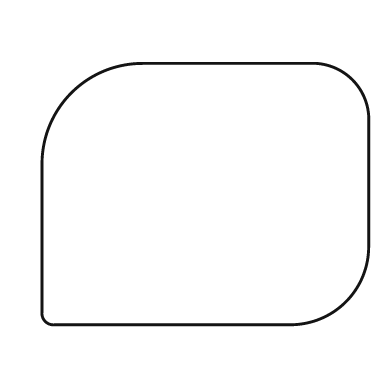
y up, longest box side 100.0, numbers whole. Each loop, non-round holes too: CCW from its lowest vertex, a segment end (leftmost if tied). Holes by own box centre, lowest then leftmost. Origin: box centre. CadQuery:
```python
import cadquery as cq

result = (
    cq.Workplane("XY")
    .moveTo(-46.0, -40.0)
    .lineTo(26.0, -40.0)
    .threePointArc((43.0, -33.0), (50.0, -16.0))
    .lineTo(50.0, 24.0)
    .threePointArc((45.0, 35.0), (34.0, 40.0))
    .lineTo(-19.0, 40.0)
    .threePointArc((-41.0, 31.0), (-50.0, 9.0))
    .lineTo(-50.0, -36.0)
    .threePointArc((-49.0, -39.0), (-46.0, -40.0))
    .close()
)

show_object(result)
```